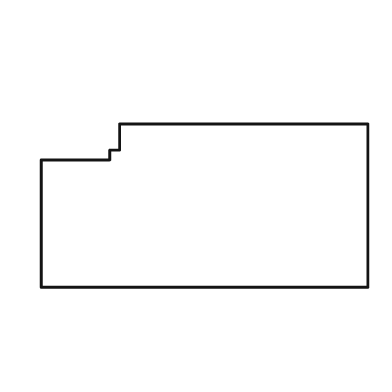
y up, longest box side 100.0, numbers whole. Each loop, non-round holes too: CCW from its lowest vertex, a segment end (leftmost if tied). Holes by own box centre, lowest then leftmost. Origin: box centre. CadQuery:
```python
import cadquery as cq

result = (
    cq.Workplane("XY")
    .moveTo(-50.0, -25.0)
    .lineTo(50.0, -25.0)
    .lineTo(50.0, 25.0)
    .lineTo(-26.0, 25.0)
    .lineTo(-26.0, 17.0)
    .lineTo(-29.0, 17.0)
    .lineTo(-29.0, 14.0)
    .lineTo(-50.0, 14.0)
    .close()
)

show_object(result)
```